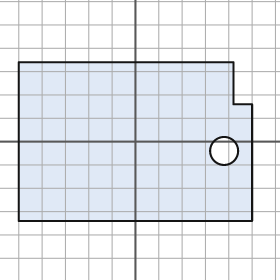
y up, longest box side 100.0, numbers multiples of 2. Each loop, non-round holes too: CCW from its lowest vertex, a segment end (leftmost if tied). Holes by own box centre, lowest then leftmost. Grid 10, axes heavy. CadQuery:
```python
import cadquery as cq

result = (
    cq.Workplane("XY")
    .moveTo(-50.0, -34.0)
    .lineTo(50.0, -34.0)
    .lineTo(50.0, 16.0)
    .lineTo(42.0, 16.0)
    .lineTo(42.0, 34.0)
    .lineTo(-50.0, 34.0)
    .close()
    .moveTo(38.0, -4.0)
    .circle(6.0)
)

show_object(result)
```